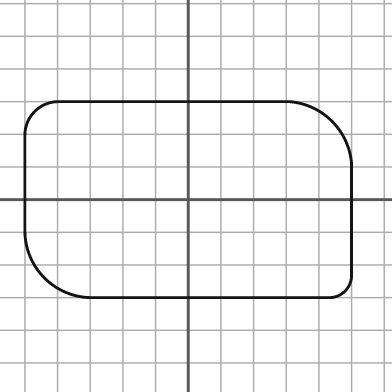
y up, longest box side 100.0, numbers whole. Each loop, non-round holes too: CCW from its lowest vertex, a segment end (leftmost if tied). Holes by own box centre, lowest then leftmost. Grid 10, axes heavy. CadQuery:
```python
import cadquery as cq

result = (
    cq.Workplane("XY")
    .moveTo(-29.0, -30.0)
    .lineTo(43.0, -30.0)
    .threePointArc((48.0, -28.0), (50.0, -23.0))
    .lineTo(50.0, 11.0)
    .threePointArc((44.0, 24.0), (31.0, 30.0))
    .lineTo(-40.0, 30.0)
    .threePointArc((-47.0, 27.0), (-50.0, 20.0))
    .lineTo(-50.0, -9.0)
    .threePointArc((-44.0, -24.0), (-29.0, -30.0))
    .close()
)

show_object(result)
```